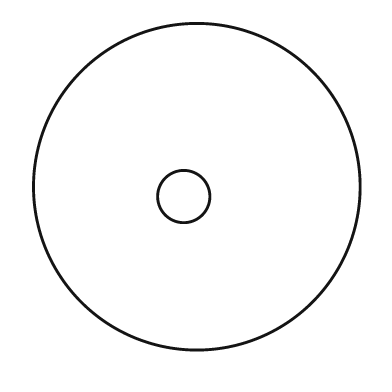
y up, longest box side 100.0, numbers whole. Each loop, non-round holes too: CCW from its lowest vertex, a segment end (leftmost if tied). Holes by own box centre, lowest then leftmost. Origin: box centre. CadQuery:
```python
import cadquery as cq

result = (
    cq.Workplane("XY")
    .moveTo(0.0, 0.0)
    .circle(50.0)
    .moveTo(-4.0, -3.0)
    .circle(8.0)
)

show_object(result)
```